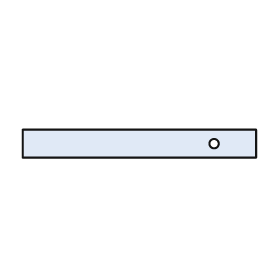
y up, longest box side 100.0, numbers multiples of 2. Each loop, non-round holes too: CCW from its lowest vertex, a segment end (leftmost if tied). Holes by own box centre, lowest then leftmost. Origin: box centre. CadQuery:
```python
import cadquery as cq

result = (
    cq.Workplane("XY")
    .moveTo(-50.0, -6.0)
    .lineTo(50.0, -6.0)
    .lineTo(50.0, 6.0)
    .lineTo(-50.0, 6.0)
    .close()
    .moveTo(32.0, 0.0)
    .circle(2.0)
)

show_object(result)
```